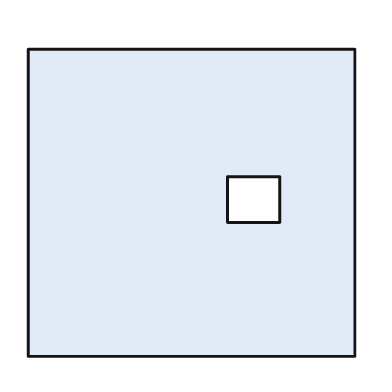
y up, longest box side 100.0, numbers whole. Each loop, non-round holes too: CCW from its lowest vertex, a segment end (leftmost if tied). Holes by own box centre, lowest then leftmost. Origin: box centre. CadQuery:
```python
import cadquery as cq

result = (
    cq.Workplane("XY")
    .moveTo(-50.0, -47.0)
    .lineTo(50.0, -47.0)
    .lineTo(50.0, 47.0)
    .lineTo(-50.0, 47.0)
    .close()
    .moveTo(11.0, -6.0)
    .lineTo(27.0, -6.0)
    .lineTo(27.0, 8.0)
    .lineTo(11.0, 8.0)
    .close()
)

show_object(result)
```